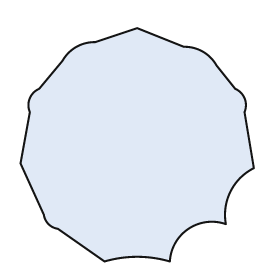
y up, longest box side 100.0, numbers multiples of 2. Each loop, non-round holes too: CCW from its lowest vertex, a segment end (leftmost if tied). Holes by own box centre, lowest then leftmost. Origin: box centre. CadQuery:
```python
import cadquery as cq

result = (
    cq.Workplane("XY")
    .moveTo(-14.0, -50.0)
    .threePointArc((0.0, -48.0), (14.0, -50.0))
    .threePointArc((22.0, -36.0), (38.0, -34.0))
    .threePointArc((40.0, -20.0), (50.0, -10.0))
    .lineTo(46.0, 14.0)
    .threePointArc((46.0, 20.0), (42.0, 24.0))
    .lineTo(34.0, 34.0)
    .threePointArc((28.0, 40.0), (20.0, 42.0))
    .lineTo(0.0, 50.0)
    .lineTo(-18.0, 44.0)
    .threePointArc((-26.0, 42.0), (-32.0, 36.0))
    .lineTo(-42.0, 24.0)
    .threePointArc((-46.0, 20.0), (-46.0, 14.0))
    .lineTo(-50.0, -8.0)
    .lineTo(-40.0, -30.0)
    .threePointArc((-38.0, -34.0), (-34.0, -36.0))
    .close()
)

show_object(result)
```